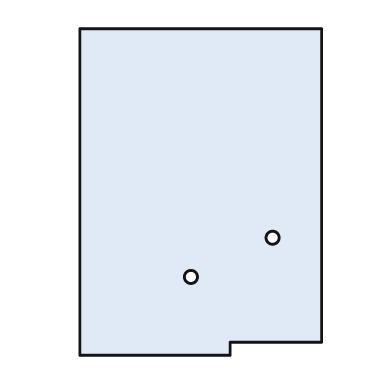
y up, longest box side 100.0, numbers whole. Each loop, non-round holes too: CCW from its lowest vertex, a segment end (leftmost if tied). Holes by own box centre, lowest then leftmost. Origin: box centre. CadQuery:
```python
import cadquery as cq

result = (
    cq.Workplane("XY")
    .moveTo(-37.0, -50.0)
    .lineTo(9.0, -50.0)
    .lineTo(9.0, -46.0)
    .lineTo(37.0, -46.0)
    .lineTo(37.0, 50.0)
    .lineTo(-37.0, 50.0)
    .close()
    .moveTo(-3.0, -26.0)
    .circle(2.0)
    .moveTo(22.0, -14.0)
    .circle(2.0)
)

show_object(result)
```